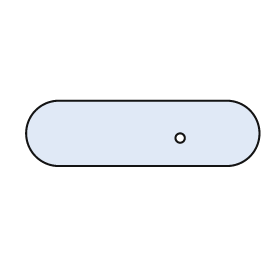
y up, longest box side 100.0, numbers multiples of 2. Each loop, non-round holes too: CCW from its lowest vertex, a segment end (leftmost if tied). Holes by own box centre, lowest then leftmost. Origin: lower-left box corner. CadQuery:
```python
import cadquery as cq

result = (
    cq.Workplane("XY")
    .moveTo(14.0, 0.0)
    .lineTo(86.0, 0.0)
    .threePointArc((100.0, 14.0), (86.0, 28.0))
    .lineTo(14.0, 28.0)
    .threePointArc((0.0, 14.0), (14.0, 0.0))
    .close()
    .moveTo(66.0, 12.0)
    .circle(2.0)
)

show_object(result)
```